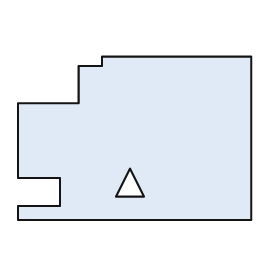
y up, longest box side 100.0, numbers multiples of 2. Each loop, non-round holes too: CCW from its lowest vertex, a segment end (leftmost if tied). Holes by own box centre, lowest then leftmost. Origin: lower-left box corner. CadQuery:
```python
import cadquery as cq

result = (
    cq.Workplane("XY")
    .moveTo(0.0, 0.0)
    .lineTo(100.0, 0.0)
    .lineTo(100.0, 70.0)
    .lineTo(36.0, 70.0)
    .lineTo(36.0, 66.0)
    .lineTo(26.0, 66.0)
    .lineTo(26.0, 50.0)
    .lineTo(0.0, 50.0)
    .lineTo(0.0, 18.0)
    .lineTo(18.0, 18.0)
    .lineTo(18.0, 6.0)
    .lineTo(0.0, 6.0)
    .close()
    .moveTo(42.0, 10.0)
    .lineTo(54.0, 10.0)
    .lineTo(48.0, 22.0)
    .close()
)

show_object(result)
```